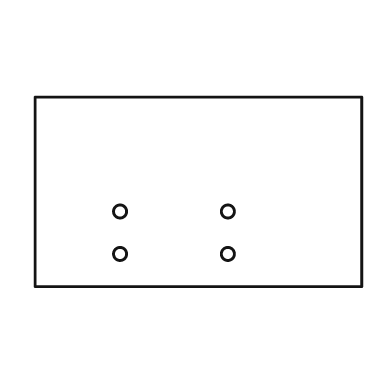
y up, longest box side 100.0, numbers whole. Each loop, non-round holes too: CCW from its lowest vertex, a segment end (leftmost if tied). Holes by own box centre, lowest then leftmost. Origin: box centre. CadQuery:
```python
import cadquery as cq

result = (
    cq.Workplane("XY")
    .moveTo(-50.0, -29.0)
    .lineTo(50.0, -29.0)
    .lineTo(50.0, 29.0)
    .lineTo(-50.0, 29.0)
    .close()
    .moveTo(-24.0, -19.0)
    .circle(2.0)
    .moveTo(9.0, -19.0)
    .circle(2.0)
    .moveTo(-24.0, -6.0)
    .circle(2.0)
    .moveTo(9.0, -6.0)
    .circle(2.0)
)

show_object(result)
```